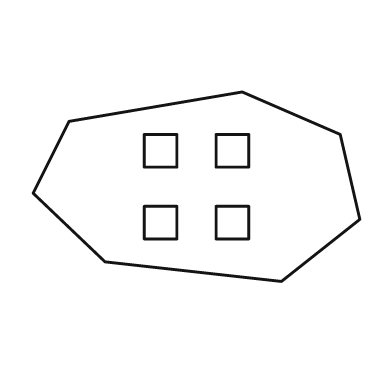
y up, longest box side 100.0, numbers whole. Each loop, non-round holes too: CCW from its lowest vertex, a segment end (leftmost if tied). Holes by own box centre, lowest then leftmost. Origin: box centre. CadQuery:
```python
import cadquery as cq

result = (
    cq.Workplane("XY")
    .moveTo(26.0, -29.0)
    .lineTo(50.0, -10.0)
    .lineTo(44.0, 16.0)
    .lineTo(14.0, 29.0)
    .lineTo(-39.0, 20.0)
    .lineTo(-50.0, -2.0)
    .lineTo(-28.0, -23.0)
    .close()
    .moveTo(-16.0, -16.0)
    .lineTo(-6.0, -16.0)
    .lineTo(-6.0, -6.0)
    .lineTo(-16.0, -6.0)
    .close()
    .moveTo(6.0, -16.0)
    .lineTo(16.0, -16.0)
    .lineTo(16.0, -6.0)
    .lineTo(6.0, -6.0)
    .close()
    .moveTo(-16.0, 6.0)
    .lineTo(-6.0, 6.0)
    .lineTo(-6.0, 16.0)
    .lineTo(-16.0, 16.0)
    .close()
    .moveTo(6.0, 6.0)
    .lineTo(16.0, 6.0)
    .lineTo(16.0, 16.0)
    .lineTo(6.0, 16.0)
    .close()
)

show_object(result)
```